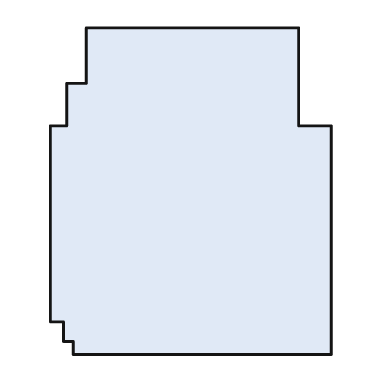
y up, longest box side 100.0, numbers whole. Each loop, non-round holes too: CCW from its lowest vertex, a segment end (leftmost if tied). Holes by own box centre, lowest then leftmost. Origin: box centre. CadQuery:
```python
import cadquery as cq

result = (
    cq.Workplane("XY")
    .moveTo(-36.0, -50.0)
    .lineTo(43.0, -50.0)
    .lineTo(43.0, 20.0)
    .lineTo(33.0, 20.0)
    .lineTo(33.0, 50.0)
    .lineTo(-32.0, 50.0)
    .lineTo(-32.0, 33.0)
    .lineTo(-38.0, 33.0)
    .lineTo(-38.0, 20.0)
    .lineTo(-43.0, 20.0)
    .lineTo(-43.0, -40.0)
    .lineTo(-39.0, -40.0)
    .lineTo(-39.0, -46.0)
    .lineTo(-36.0, -46.0)
    .close()
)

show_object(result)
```